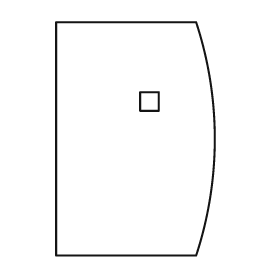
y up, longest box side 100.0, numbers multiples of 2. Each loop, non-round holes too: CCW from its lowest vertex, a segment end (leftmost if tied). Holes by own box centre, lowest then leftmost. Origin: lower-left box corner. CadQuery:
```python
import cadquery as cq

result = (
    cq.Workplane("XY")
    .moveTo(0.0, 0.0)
    .lineTo(60.0, 0.0)
    .threePointArc((68.0, 50.0), (60.0, 100.0))
    .lineTo(0.0, 100.0)
    .close()
    .moveTo(36.0, 62.0)
    .lineTo(44.0, 62.0)
    .lineTo(44.0, 70.0)
    .lineTo(36.0, 70.0)
    .close()
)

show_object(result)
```